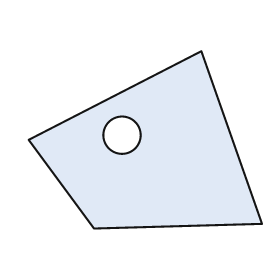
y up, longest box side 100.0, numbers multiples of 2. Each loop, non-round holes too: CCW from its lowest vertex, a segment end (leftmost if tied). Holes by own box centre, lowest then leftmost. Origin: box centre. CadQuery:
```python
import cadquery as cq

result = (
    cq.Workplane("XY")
    .moveTo(-22.0, -38.0)
    .lineTo(50.0, -36.0)
    .lineTo(24.0, 38.0)
    .lineTo(-50.0, 0.0)
    .close()
    .moveTo(-10.0, 2.0)
    .circle(8.0)
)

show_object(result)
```